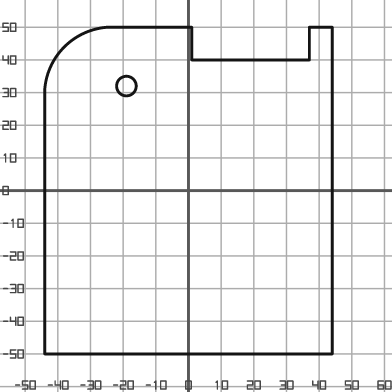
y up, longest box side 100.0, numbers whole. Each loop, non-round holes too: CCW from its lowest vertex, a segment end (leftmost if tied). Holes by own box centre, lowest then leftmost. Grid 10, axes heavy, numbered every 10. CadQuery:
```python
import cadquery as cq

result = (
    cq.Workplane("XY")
    .moveTo(-44.0, -50.0)
    .lineTo(44.0, -50.0)
    .lineTo(44.0, 50.0)
    .lineTo(37.0, 50.0)
    .lineTo(37.0, 40.0)
    .lineTo(1.0, 40.0)
    .lineTo(1.0, 50.0)
    .lineTo(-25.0, 50.0)
    .threePointArc((-38.0, 44.0), (-44.0, 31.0))
    .close()
    .moveTo(-19.0, 32.0)
    .circle(3.0)
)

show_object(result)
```